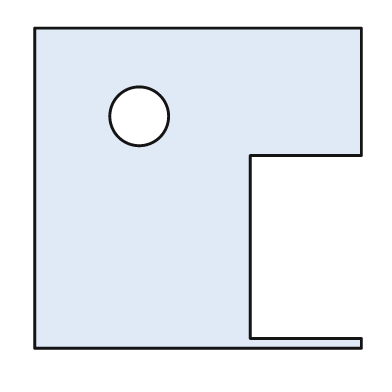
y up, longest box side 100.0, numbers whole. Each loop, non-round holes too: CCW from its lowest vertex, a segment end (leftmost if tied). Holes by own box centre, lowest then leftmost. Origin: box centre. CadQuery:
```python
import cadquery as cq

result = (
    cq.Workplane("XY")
    .moveTo(-50.0, -49.0)
    .lineTo(50.0, -49.0)
    .lineTo(50.0, -46.0)
    .lineTo(16.0, -46.0)
    .lineTo(16.0, 10.0)
    .lineTo(50.0, 10.0)
    .lineTo(50.0, 49.0)
    .lineTo(-50.0, 49.0)
    .close()
    .moveTo(-18.0, 22.0)
    .circle(9.0)
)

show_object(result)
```